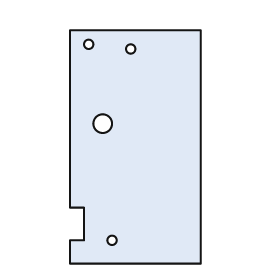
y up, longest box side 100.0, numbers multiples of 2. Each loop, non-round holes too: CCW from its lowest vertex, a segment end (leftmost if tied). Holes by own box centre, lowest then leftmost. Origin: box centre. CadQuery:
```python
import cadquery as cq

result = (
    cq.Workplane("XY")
    .moveTo(-28.0, -50.0)
    .lineTo(28.0, -50.0)
    .lineTo(28.0, 50.0)
    .lineTo(-28.0, 50.0)
    .lineTo(-28.0, -26.0)
    .lineTo(-22.0, -26.0)
    .lineTo(-22.0, -40.0)
    .lineTo(-28.0, -40.0)
    .close()
    .moveTo(-10.0, -40.0)
    .circle(2.0)
    .moveTo(-14.0, 10.0)
    .circle(4.0)
    .moveTo(-2.0, 42.0)
    .circle(2.0)
    .moveTo(-20.0, 44.0)
    .circle(2.0)
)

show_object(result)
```